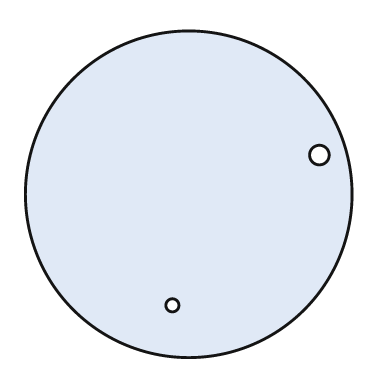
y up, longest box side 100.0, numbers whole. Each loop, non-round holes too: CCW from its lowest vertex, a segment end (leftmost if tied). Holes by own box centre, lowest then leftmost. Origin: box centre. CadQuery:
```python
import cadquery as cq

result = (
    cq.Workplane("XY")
    .moveTo(0.0, 0.0)
    .circle(50.0)
    .moveTo(-5.0, -34.0)
    .circle(2.0)
    .moveTo(40.0, 12.0)
    .circle(3.0)
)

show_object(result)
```